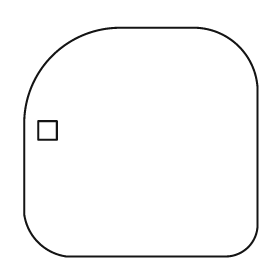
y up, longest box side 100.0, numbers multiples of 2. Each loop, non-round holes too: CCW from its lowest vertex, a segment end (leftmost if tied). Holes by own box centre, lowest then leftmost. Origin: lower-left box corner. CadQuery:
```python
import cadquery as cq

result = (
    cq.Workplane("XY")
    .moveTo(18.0, 0.0)
    .lineTo(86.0, 0.0)
    .threePointArc((96.0, 4.0), (100.0, 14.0))
    .lineTo(100.0, 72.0)
    .threePointArc((92.0, 90.0), (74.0, 98.0))
    .lineTo(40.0, 98.0)
    .threePointArc((12.0, 86.0), (0.0, 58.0))
    .lineTo(0.0, 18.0)
    .threePointArc((6.0, 6.0), (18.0, 0.0))
    .close()
    .moveTo(6.0, 50.0)
    .lineTo(14.0, 50.0)
    .lineTo(14.0, 58.0)
    .lineTo(6.0, 58.0)
    .close()
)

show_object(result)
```